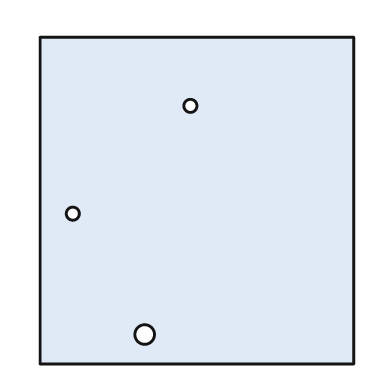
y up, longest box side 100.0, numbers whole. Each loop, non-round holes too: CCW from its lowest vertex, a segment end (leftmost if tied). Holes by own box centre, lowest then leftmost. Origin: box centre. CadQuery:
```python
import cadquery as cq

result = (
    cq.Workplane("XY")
    .moveTo(-48.0, -50.0)
    .lineTo(48.0, -50.0)
    .lineTo(48.0, 50.0)
    .lineTo(-48.0, 50.0)
    .close()
    .moveTo(-16.0, -41.0)
    .circle(3.0)
    .moveTo(-38.0, -4.0)
    .circle(2.0)
    .moveTo(-2.0, 29.0)
    .circle(2.0)
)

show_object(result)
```